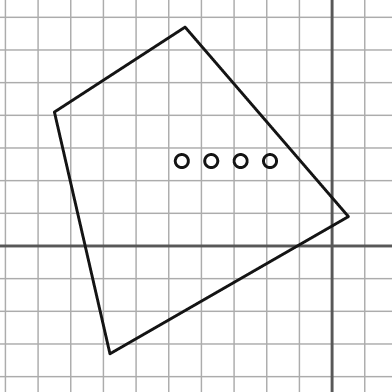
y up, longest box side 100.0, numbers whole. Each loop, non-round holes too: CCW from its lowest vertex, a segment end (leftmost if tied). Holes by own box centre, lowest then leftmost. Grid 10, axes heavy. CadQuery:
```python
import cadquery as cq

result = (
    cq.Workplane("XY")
    .moveTo(-68.0, -33.0)
    .lineTo(5.0, 9.0)
    .lineTo(-45.0, 67.0)
    .lineTo(-85.0, 41.0)
    .close()
    .moveTo(-46.0, 26.0)
    .circle(2.0)
    .moveTo(-37.0, 26.0)
    .circle(2.0)
    .moveTo(-28.0, 26.0)
    .circle(2.0)
    .moveTo(-19.0, 26.0)
    .circle(2.0)
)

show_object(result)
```